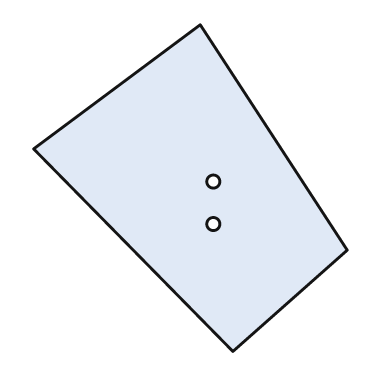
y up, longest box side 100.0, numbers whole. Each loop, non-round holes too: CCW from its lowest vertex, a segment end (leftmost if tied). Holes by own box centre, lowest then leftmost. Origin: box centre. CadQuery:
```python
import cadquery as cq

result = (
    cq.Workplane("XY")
    .moveTo(13.0, -50.0)
    .lineTo(48.0, -19.0)
    .lineTo(3.0, 50.0)
    .lineTo(-48.0, 12.0)
    .close()
    .moveTo(7.0, -11.0)
    .circle(2.0)
    .moveTo(7.0, 2.0)
    .circle(2.0)
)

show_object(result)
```